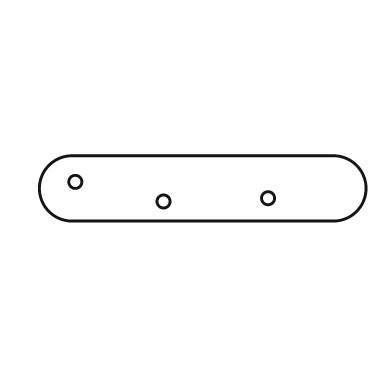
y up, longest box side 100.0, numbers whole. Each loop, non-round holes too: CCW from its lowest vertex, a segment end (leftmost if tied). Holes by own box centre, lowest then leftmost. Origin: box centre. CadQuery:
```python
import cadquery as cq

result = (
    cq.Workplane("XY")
    .moveTo(-40.0, -10.0)
    .lineTo(40.0, -10.0)
    .threePointArc((50.0, 0.0), (40.0, 10.0))
    .lineTo(-40.0, 10.0)
    .threePointArc((-50.0, 0.0), (-40.0, -10.0))
    .close()
    .moveTo(-12.0, -4.0)
    .circle(2.0)
    .moveTo(20.0, -3.0)
    .circle(2.0)
    .moveTo(-39.0, 2.0)
    .circle(2.0)
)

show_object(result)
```